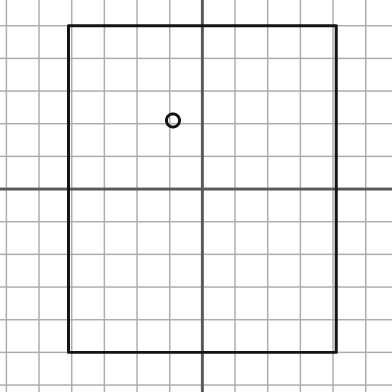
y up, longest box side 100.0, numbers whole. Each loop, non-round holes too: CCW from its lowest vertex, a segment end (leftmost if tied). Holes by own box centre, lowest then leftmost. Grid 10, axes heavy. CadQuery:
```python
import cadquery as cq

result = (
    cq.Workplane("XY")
    .moveTo(-41.0, -50.0)
    .lineTo(41.0, -50.0)
    .lineTo(41.0, 50.0)
    .lineTo(-41.0, 50.0)
    .close()
    .moveTo(-9.0, 21.0)
    .circle(2.0)
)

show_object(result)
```